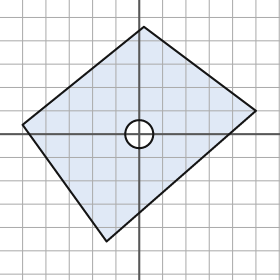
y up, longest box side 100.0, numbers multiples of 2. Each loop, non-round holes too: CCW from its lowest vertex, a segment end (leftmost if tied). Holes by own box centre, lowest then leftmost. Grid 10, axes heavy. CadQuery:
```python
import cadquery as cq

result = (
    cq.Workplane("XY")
    .moveTo(-14.0, -46.0)
    .lineTo(50.0, 10.0)
    .lineTo(2.0, 46.0)
    .lineTo(-50.0, 4.0)
    .close()
    .moveTo(0.0, 0.0)
    .circle(6.0)
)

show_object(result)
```